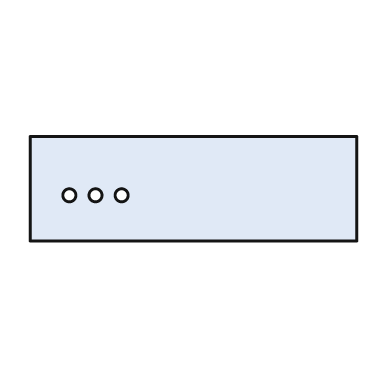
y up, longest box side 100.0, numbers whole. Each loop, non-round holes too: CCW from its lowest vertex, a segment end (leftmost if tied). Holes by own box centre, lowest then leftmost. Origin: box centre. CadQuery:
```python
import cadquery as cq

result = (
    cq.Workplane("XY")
    .moveTo(-50.0, -16.0)
    .lineTo(50.0, -16.0)
    .lineTo(50.0, 16.0)
    .lineTo(-50.0, 16.0)
    .close()
    .moveTo(-38.0, -2.0)
    .circle(2.0)
    .moveTo(-30.0, -2.0)
    .circle(2.0)
    .moveTo(-22.0, -2.0)
    .circle(2.0)
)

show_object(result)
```